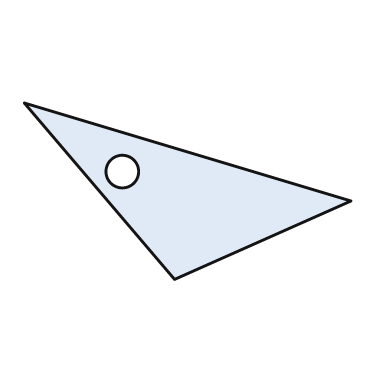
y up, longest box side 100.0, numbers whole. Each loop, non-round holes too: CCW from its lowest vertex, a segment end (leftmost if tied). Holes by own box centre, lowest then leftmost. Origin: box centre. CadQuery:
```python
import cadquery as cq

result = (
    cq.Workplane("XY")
    .moveTo(-4.0, -27.0)
    .lineTo(50.0, -3.0)
    .lineTo(-50.0, 27.0)
    .close()
    .moveTo(-20.0, 6.0)
    .circle(5.0)
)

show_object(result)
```